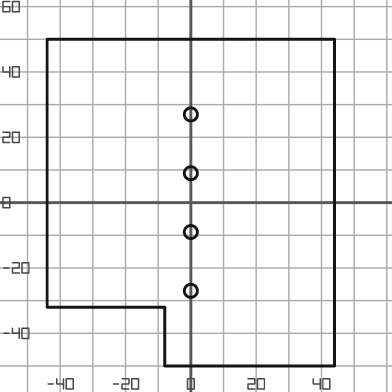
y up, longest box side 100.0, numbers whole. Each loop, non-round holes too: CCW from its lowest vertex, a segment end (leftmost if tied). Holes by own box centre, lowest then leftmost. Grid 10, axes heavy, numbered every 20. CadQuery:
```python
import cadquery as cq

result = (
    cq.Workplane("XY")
    .moveTo(-8.0, -50.0)
    .lineTo(44.0, -50.0)
    .lineTo(44.0, 50.0)
    .lineTo(-44.0, 50.0)
    .lineTo(-44.0, -32.0)
    .lineTo(-8.0, -32.0)
    .close()
    .moveTo(0.0, -27.0)
    .circle(2.0)
    .moveTo(0.0, -9.0)
    .circle(2.0)
    .moveTo(0.0, 9.0)
    .circle(2.0)
    .moveTo(0.0, 27.0)
    .circle(2.0)
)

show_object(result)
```